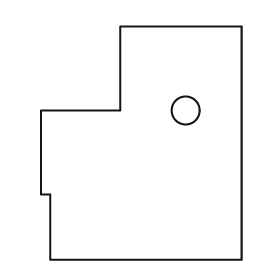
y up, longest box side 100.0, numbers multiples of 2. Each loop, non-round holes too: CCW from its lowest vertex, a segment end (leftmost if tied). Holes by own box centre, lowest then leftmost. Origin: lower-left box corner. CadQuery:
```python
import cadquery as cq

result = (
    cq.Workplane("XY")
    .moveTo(4.0, 0.0)
    .lineTo(86.0, 0.0)
    .lineTo(86.0, 100.0)
    .lineTo(34.0, 100.0)
    .lineTo(34.0, 64.0)
    .lineTo(0.0, 64.0)
    .lineTo(0.0, 28.0)
    .lineTo(4.0, 28.0)
    .close()
    .moveTo(62.0, 64.0)
    .circle(6.0)
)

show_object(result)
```